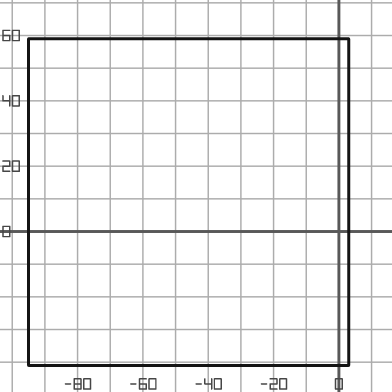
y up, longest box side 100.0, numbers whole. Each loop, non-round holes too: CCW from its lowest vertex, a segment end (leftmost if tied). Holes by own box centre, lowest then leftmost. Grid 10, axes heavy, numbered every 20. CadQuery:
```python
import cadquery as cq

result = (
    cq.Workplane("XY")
    .moveTo(-95.0, -41.0)
    .lineTo(3.0, -41.0)
    .lineTo(3.0, 59.0)
    .lineTo(-95.0, 59.0)
    .close()
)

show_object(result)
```